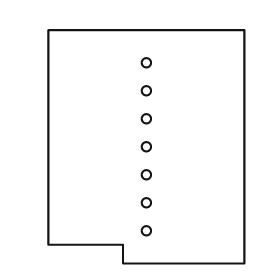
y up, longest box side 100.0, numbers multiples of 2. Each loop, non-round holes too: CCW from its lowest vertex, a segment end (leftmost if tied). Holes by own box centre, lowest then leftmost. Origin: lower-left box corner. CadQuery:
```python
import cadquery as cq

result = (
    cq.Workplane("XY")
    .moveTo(32.0, 0.0)
    .lineTo(84.0, 0.0)
    .lineTo(84.0, 100.0)
    .lineTo(0.0, 100.0)
    .lineTo(0.0, 8.0)
    .lineTo(32.0, 8.0)
    .close()
    .moveTo(42.0, 14.0)
    .circle(2.0)
    .moveTo(42.0, 26.0)
    .circle(2.0)
    .moveTo(42.0, 38.0)
    .circle(2.0)
    .moveTo(42.0, 50.0)
    .circle(2.0)
    .moveTo(42.0, 62.0)
    .circle(2.0)
    .moveTo(42.0, 74.0)
    .circle(2.0)
    .moveTo(42.0, 86.0)
    .circle(2.0)
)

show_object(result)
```